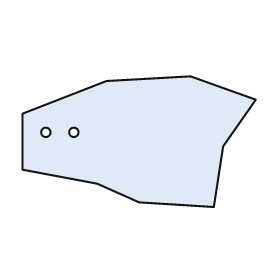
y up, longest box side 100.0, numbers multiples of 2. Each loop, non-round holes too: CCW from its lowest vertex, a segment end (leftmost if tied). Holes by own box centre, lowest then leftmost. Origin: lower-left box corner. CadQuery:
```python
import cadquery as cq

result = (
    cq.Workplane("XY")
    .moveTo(82.0, 0.0)
    .lineTo(86.0, 26.0)
    .lineTo(100.0, 46.0)
    .lineTo(72.0, 56.0)
    .lineTo(36.0, 54.0)
    .lineTo(0.0, 40.0)
    .lineTo(0.0, 16.0)
    .lineTo(32.0, 10.0)
    .lineTo(50.0, 2.0)
    .close()
    .moveTo(10.0, 32.0)
    .circle(2.0)
    .moveTo(22.0, 32.0)
    .circle(2.0)
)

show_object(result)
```